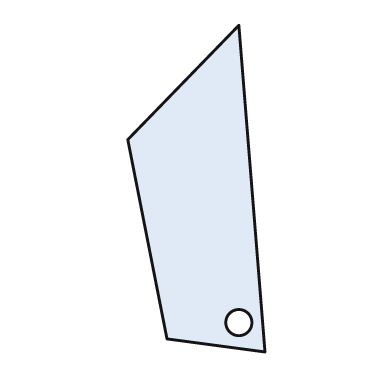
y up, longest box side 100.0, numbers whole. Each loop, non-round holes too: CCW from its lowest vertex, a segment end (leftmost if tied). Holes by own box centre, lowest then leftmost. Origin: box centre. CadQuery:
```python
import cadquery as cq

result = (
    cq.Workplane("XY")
    .moveTo(21.0, -50.0)
    .lineTo(13.0, 50.0)
    .lineTo(-21.0, 15.0)
    .lineTo(-9.0, -46.0)
    .close()
    .moveTo(13.0, -41.0)
    .circle(4.0)
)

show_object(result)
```